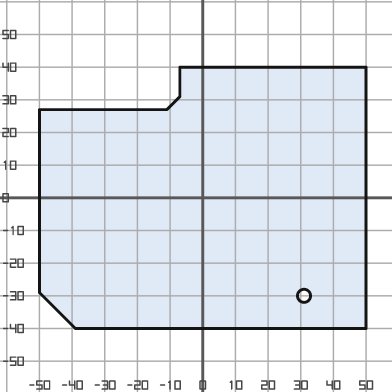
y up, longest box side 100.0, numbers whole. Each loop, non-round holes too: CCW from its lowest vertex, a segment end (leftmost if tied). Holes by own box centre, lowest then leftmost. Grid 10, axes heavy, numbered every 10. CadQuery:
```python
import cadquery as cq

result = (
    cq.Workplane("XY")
    .moveTo(-39.0, -40.0)
    .lineTo(50.0, -40.0)
    .lineTo(50.0, 40.0)
    .lineTo(-7.0, 40.0)
    .lineTo(-7.0, 31.0)
    .lineTo(-11.0, 27.0)
    .lineTo(-50.0, 27.0)
    .lineTo(-50.0, -29.0)
    .close()
    .moveTo(31.0, -30.0)
    .circle(2.0)
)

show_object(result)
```